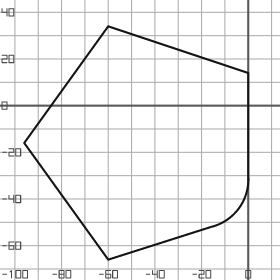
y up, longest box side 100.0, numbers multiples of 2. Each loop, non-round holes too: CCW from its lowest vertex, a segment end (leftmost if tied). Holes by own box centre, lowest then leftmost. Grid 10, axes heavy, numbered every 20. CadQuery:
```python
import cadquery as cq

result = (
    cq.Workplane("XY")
    .moveTo(-60.0, -66.0)
    .lineTo(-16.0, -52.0)
    .threePointArc((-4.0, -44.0), (0.0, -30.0))
    .lineTo(0.0, 14.0)
    .lineTo(-60.0, 34.0)
    .lineTo(-96.0, -16.0)
    .close()
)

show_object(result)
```